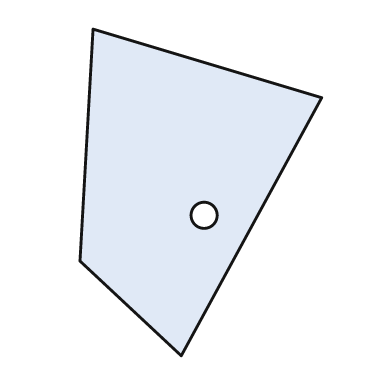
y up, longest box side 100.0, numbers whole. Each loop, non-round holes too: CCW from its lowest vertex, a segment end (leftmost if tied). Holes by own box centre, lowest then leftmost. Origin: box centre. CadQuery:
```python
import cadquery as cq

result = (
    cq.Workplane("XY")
    .moveTo(-6.0, -50.0)
    .lineTo(37.0, 29.0)
    .lineTo(-33.0, 50.0)
    .lineTo(-37.0, -21.0)
    .close()
    .moveTo(1.0, -7.0)
    .circle(4.0)
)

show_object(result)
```